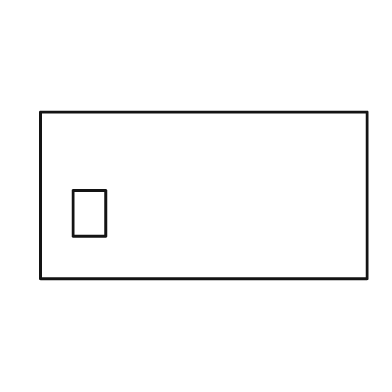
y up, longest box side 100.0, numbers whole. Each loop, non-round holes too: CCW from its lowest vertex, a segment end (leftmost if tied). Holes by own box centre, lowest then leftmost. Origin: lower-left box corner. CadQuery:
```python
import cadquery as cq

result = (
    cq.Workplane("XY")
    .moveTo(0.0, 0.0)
    .lineTo(100.0, 0.0)
    .lineTo(100.0, 51.0)
    .lineTo(0.0, 51.0)
    .close()
    .moveTo(10.0, 13.0)
    .lineTo(20.0, 13.0)
    .lineTo(20.0, 27.0)
    .lineTo(10.0, 27.0)
    .close()
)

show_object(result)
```